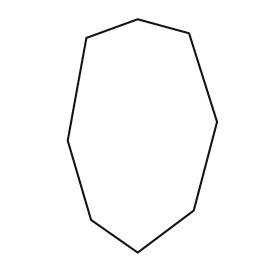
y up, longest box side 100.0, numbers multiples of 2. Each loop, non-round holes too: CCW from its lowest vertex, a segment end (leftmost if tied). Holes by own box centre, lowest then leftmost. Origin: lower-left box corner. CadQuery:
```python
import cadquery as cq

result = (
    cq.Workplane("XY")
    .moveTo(30.0, 0.0)
    .lineTo(54.0, 18.0)
    .lineTo(64.0, 56.0)
    .lineTo(52.0, 94.0)
    .lineTo(30.0, 100.0)
    .lineTo(8.0, 92.0)
    .lineTo(0.0, 48.0)
    .lineTo(10.0, 14.0)
    .close()
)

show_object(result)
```